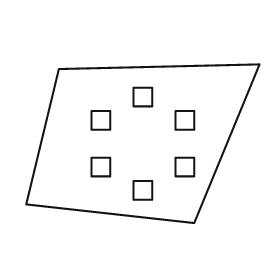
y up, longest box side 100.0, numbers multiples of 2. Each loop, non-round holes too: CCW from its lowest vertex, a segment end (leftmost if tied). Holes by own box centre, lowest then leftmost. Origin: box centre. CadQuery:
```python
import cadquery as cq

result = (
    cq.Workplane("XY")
    .moveTo(22.0, -34.0)
    .lineTo(50.0, 34.0)
    .lineTo(-36.0, 32.0)
    .lineTo(-50.0, -26.0)
    .close()
    .moveTo(-4.0, -24.0)
    .lineTo(4.0, -24.0)
    .lineTo(4.0, -16.0)
    .lineTo(-4.0, -16.0)
    .close()
    .moveTo(-22.0, -14.0)
    .lineTo(-14.0, -14.0)
    .lineTo(-14.0, -6.0)
    .lineTo(-22.0, -6.0)
    .close()
    .moveTo(14.0, -14.0)
    .lineTo(22.0, -14.0)
    .lineTo(22.0, -6.0)
    .lineTo(14.0, -6.0)
    .close()
    .moveTo(-22.0, 6.0)
    .lineTo(-14.0, 6.0)
    .lineTo(-14.0, 14.0)
    .lineTo(-22.0, 14.0)
    .close()
    .moveTo(14.0, 6.0)
    .lineTo(22.0, 6.0)
    .lineTo(22.0, 14.0)
    .lineTo(14.0, 14.0)
    .close()
    .moveTo(-4.0, 16.0)
    .lineTo(4.0, 16.0)
    .lineTo(4.0, 24.0)
    .lineTo(-4.0, 24.0)
    .close()
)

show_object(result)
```